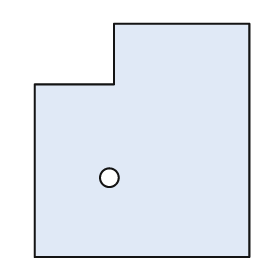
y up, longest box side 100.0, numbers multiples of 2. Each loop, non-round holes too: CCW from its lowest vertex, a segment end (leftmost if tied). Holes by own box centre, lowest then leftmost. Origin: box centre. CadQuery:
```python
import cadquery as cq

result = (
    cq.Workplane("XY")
    .moveTo(-46.0, -50.0)
    .lineTo(46.0, -50.0)
    .lineTo(46.0, 50.0)
    .lineTo(-12.0, 50.0)
    .lineTo(-12.0, 24.0)
    .lineTo(-46.0, 24.0)
    .close()
    .moveTo(-14.0, -16.0)
    .circle(4.0)
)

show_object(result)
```